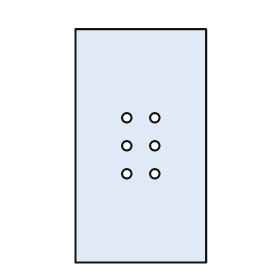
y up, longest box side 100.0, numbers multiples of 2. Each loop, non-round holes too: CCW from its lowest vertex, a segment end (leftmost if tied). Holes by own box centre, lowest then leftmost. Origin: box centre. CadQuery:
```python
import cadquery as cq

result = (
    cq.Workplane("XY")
    .moveTo(-28.0, -50.0)
    .lineTo(28.0, -50.0)
    .lineTo(28.0, 50.0)
    .lineTo(-28.0, 50.0)
    .close()
    .moveTo(-6.0, -12.0)
    .circle(2.0)
    .moveTo(6.0, -12.0)
    .circle(2.0)
    .moveTo(-6.0, 0.0)
    .circle(2.0)
    .moveTo(6.0, 0.0)
    .circle(2.0)
    .moveTo(-6.0, 12.0)
    .circle(2.0)
    .moveTo(6.0, 12.0)
    .circle(2.0)
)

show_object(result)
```